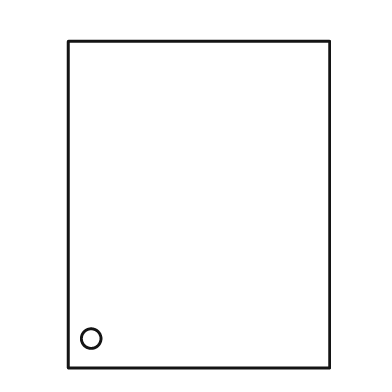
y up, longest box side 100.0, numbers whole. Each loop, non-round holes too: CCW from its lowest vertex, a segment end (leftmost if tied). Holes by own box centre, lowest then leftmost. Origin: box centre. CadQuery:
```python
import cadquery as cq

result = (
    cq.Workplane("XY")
    .moveTo(-40.0, -50.0)
    .lineTo(40.0, -50.0)
    .lineTo(40.0, 50.0)
    .lineTo(-40.0, 50.0)
    .close()
    .moveTo(-33.0, -41.0)
    .circle(3.0)
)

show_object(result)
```